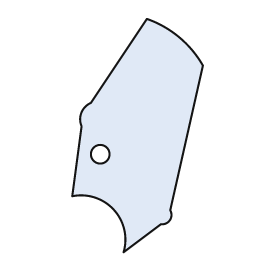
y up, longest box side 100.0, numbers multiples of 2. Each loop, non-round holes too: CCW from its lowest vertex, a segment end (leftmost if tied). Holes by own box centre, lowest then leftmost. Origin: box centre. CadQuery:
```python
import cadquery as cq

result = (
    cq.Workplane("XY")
    .moveTo(-6.0, -50.0)
    .lineTo(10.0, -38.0)
    .threePointArc((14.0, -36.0), (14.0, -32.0))
    .lineTo(28.0, 30.0)
    .threePointArc((18.0, 42.0), (4.0, 50.0))
    .lineTo(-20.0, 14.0)
    .threePointArc((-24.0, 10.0), (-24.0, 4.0))
    .lineTo(-28.0, -26.0)
    .threePointArc((-10.0, -32.0), (-6.0, -50.0))
    .close()
    .moveTo(-16.0, -8.0)
    .circle(4.0)
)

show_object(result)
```